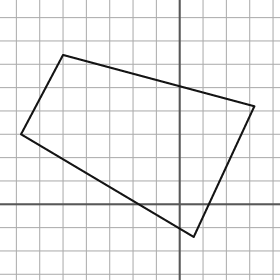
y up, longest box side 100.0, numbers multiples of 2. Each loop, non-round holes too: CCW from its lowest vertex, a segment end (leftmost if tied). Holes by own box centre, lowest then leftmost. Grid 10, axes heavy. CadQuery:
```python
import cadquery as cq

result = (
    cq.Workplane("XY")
    .moveTo(6.0, -14.0)
    .lineTo(32.0, 42.0)
    .lineTo(-50.0, 64.0)
    .lineTo(-68.0, 30.0)
    .close()
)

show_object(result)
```